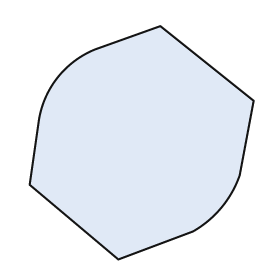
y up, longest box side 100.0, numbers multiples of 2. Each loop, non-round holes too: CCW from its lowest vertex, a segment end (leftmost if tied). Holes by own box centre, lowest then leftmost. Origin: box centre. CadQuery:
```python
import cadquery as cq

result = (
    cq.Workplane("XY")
    .moveTo(-10.0, -50.0)
    .lineTo(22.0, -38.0)
    .threePointArc((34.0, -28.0), (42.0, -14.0))
    .lineTo(48.0, 18.0)
    .lineTo(8.0, 50.0)
    .lineTo(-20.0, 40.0)
    .threePointArc((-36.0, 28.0), (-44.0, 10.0))
    .lineTo(-48.0, -18.0)
    .close()
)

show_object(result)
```